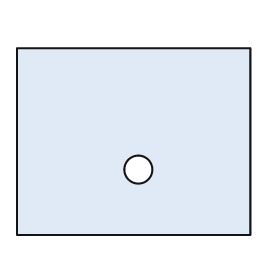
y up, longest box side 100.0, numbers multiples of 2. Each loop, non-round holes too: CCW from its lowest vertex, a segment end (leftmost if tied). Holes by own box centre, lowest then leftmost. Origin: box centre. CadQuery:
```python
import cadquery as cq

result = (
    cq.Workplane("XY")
    .moveTo(-50.0, -40.0)
    .lineTo(50.0, -40.0)
    .lineTo(50.0, 40.0)
    .lineTo(-50.0, 40.0)
    .close()
    .moveTo(2.0, -12.0)
    .circle(6.0)
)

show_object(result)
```